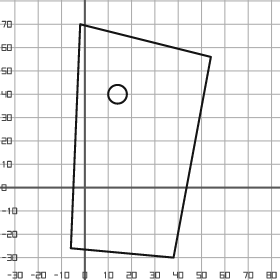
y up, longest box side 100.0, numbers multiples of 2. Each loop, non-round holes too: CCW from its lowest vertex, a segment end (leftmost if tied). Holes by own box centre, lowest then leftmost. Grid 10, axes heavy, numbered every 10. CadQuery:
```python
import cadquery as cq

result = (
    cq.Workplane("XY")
    .moveTo(38.0, -30.0)
    .lineTo(54.0, 56.0)
    .lineTo(-2.0, 70.0)
    .lineTo(-6.0, -26.0)
    .close()
    .moveTo(14.0, 40.0)
    .circle(4.0)
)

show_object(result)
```